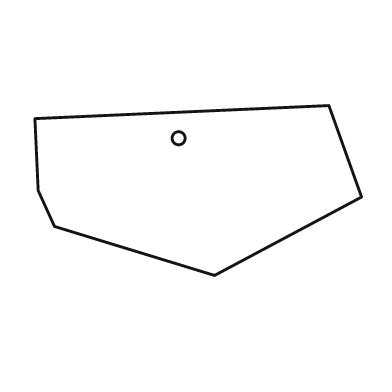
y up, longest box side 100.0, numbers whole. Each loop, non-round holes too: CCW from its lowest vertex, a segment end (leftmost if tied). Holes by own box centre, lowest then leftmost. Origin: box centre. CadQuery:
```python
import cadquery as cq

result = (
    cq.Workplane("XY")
    .moveTo(5.0, -26.0)
    .lineTo(50.0, -2.0)
    .lineTo(40.0, 26.0)
    .lineTo(-50.0, 22.0)
    .lineTo(-49.0, 0.0)
    .lineTo(-44.0, -11.0)
    .close()
    .moveTo(-6.0, 16.0)
    .circle(2.0)
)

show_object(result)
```